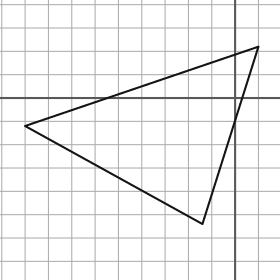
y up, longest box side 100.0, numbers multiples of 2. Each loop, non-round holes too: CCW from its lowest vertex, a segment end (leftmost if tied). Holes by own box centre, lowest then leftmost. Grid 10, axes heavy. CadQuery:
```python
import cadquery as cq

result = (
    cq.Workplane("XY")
    .moveTo(-14.0, -54.0)
    .lineTo(10.0, 22.0)
    .lineTo(-90.0, -12.0)
    .close()
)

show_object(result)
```